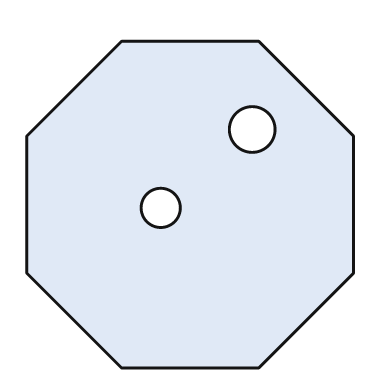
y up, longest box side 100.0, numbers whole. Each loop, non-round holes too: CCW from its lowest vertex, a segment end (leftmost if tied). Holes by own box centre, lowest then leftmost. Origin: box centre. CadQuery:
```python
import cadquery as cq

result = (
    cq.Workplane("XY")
    .moveTo(-21.0, -50.0)
    .lineTo(21.0, -50.0)
    .lineTo(50.0, -21.0)
    .lineTo(50.0, 21.0)
    .lineTo(21.0, 50.0)
    .lineTo(-21.0, 50.0)
    .lineTo(-50.0, 21.0)
    .lineTo(-50.0, -21.0)
    .close()
    .moveTo(-9.0, -1.0)
    .circle(6.0)
    .moveTo(19.0, 23.0)
    .circle(7.0)
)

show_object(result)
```